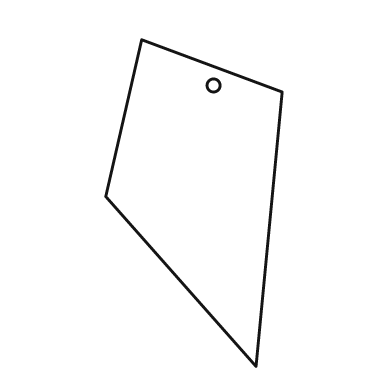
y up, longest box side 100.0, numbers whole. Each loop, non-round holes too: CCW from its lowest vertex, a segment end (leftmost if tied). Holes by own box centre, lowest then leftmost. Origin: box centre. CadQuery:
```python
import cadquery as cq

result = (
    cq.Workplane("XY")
    .moveTo(19.0, -50.0)
    .lineTo(27.0, 34.0)
    .lineTo(-16.0, 50.0)
    .lineTo(-27.0, 2.0)
    .close()
    .moveTo(6.0, 36.0)
    .circle(2.0)
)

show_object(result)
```